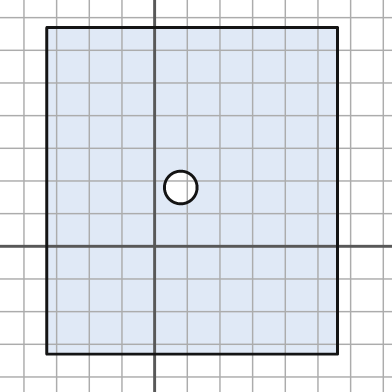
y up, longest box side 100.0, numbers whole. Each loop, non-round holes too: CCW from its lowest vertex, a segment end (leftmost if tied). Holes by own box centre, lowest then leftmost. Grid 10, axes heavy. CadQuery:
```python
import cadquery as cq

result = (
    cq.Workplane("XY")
    .moveTo(-33.0, -33.0)
    .lineTo(56.0, -33.0)
    .lineTo(56.0, 67.0)
    .lineTo(-33.0, 67.0)
    .close()
    .moveTo(8.0, 18.0)
    .circle(5.0)
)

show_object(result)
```